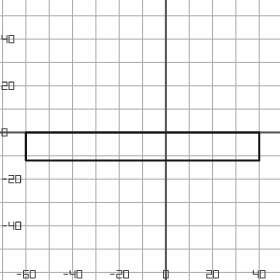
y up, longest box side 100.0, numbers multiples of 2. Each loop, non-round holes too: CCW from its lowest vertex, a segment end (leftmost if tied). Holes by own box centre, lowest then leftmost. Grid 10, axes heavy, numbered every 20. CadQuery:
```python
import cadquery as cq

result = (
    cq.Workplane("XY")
    .moveTo(-60.0, -12.0)
    .lineTo(40.0, -12.0)
    .lineTo(40.0, 0.0)
    .lineTo(-60.0, 0.0)
    .close()
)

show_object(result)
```